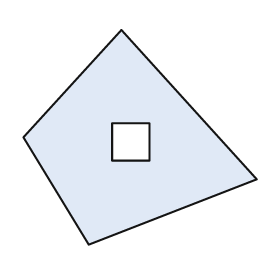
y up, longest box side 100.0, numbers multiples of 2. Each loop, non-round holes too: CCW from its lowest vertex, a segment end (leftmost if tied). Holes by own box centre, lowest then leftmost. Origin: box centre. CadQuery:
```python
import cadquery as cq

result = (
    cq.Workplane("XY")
    .moveTo(-22.0, -46.0)
    .lineTo(50.0, -18.0)
    .lineTo(-8.0, 46.0)
    .lineTo(-50.0, 0.0)
    .close()
    .moveTo(-12.0, -10.0)
    .lineTo(4.0, -10.0)
    .lineTo(4.0, 6.0)
    .lineTo(-12.0, 6.0)
    .close()
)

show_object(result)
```